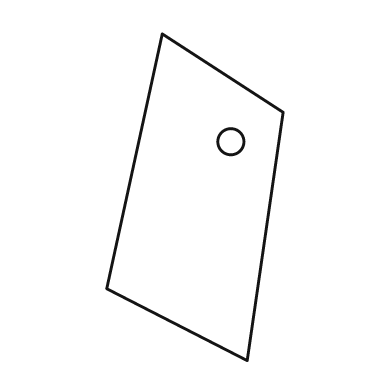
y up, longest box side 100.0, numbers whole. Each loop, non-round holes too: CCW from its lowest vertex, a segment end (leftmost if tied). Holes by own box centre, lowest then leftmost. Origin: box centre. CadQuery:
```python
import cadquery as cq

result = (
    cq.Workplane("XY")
    .moveTo(16.0, -50.0)
    .lineTo(27.0, 26.0)
    .lineTo(-10.0, 50.0)
    .lineTo(-27.0, -28.0)
    .close()
    .moveTo(11.0, 17.0)
    .circle(4.0)
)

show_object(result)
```